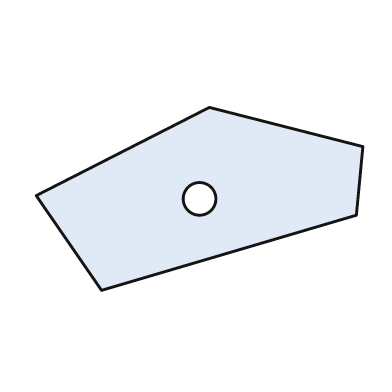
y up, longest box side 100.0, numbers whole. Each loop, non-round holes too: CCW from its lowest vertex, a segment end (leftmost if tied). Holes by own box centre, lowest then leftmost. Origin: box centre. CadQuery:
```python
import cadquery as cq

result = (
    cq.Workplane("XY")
    .moveTo(-30.0, -28.0)
    .lineTo(48.0, -5.0)
    .lineTo(50.0, 16.0)
    .lineTo(3.0, 28.0)
    .lineTo(-50.0, 1.0)
    .close()
    .moveTo(0.0, 0.0)
    .circle(5.0)
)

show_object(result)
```